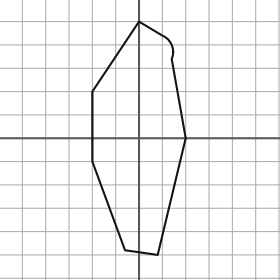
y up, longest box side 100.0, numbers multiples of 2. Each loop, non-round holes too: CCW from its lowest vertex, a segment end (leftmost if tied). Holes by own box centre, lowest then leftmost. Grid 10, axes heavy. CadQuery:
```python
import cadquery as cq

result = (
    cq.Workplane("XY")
    .moveTo(8.0, -50.0)
    .lineTo(20.0, 0.0)
    .lineTo(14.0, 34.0)
    .threePointArc((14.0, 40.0), (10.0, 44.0))
    .lineTo(0.0, 50.0)
    .lineTo(-20.0, 20.0)
    .lineTo(-20.0, -10.0)
    .lineTo(-6.0, -48.0)
    .close()
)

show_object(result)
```